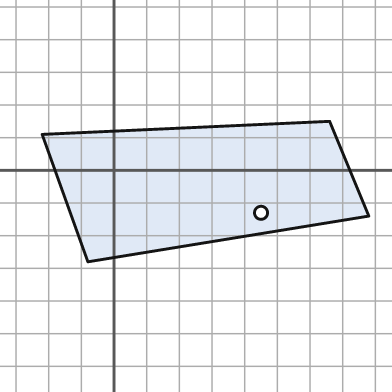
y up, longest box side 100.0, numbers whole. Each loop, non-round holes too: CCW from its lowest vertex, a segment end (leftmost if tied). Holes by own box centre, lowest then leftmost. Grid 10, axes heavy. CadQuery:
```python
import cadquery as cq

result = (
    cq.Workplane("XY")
    .moveTo(-8.0, -28.0)
    .lineTo(78.0, -14.0)
    .lineTo(66.0, 15.0)
    .lineTo(-22.0, 11.0)
    .close()
    .moveTo(45.0, -13.0)
    .circle(2.0)
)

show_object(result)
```